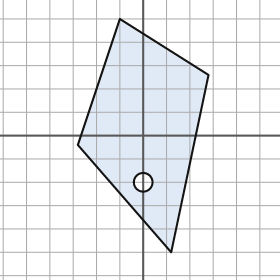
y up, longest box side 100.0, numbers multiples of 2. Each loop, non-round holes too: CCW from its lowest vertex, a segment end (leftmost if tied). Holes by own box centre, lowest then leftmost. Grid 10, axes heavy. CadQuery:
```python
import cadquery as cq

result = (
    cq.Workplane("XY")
    .moveTo(12.0, -50.0)
    .lineTo(28.0, 26.0)
    .lineTo(-10.0, 50.0)
    .lineTo(-28.0, -4.0)
    .close()
    .moveTo(0.0, -20.0)
    .circle(4.0)
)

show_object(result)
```